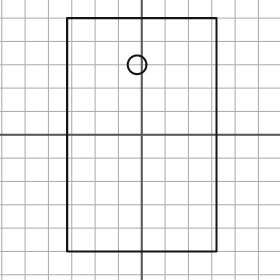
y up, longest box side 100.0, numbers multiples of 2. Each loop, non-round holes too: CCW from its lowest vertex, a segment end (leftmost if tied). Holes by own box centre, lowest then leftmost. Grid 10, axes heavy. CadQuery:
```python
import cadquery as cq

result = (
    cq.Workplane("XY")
    .moveTo(-32.0, -50.0)
    .lineTo(32.0, -50.0)
    .lineTo(32.0, 50.0)
    .lineTo(-32.0, 50.0)
    .close()
    .moveTo(-2.0, 30.0)
    .circle(4.0)
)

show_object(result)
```